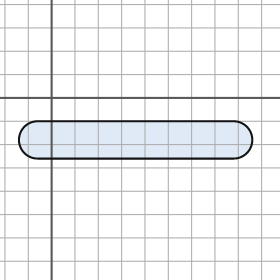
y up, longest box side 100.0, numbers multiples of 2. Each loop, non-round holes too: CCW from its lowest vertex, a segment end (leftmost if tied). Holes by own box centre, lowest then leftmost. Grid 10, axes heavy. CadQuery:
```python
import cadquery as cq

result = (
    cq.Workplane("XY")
    .moveTo(-6.0, -26.0)
    .lineTo(78.0, -26.0)
    .threePointArc((86.0, -18.0), (78.0, -10.0))
    .lineTo(-6.0, -10.0)
    .threePointArc((-14.0, -18.0), (-6.0, -26.0))
    .close()
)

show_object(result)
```